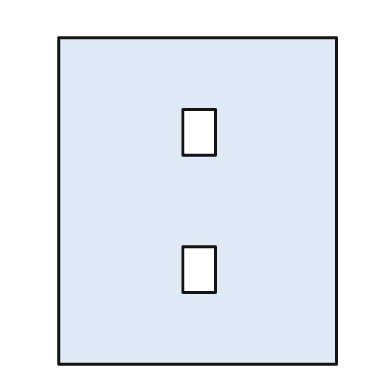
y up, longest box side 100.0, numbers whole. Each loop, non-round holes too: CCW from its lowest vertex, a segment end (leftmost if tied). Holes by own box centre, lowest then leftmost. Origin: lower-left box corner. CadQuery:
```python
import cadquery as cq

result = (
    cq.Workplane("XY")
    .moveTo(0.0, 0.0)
    .lineTo(85.0, 0.0)
    .lineTo(85.0, 100.0)
    .lineTo(0.0, 100.0)
    .close()
    .moveTo(38.0, 22.0)
    .lineTo(48.0, 22.0)
    .lineTo(48.0, 36.0)
    .lineTo(38.0, 36.0)
    .close()
    .moveTo(38.0, 64.0)
    .lineTo(48.0, 64.0)
    .lineTo(48.0, 78.0)
    .lineTo(38.0, 78.0)
    .close()
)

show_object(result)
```